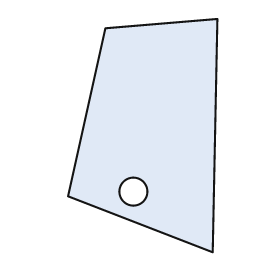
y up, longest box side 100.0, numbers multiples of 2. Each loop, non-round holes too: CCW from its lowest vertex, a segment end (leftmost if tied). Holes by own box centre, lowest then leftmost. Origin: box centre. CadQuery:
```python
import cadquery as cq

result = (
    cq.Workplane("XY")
    .moveTo(30.0, -50.0)
    .lineTo(32.0, 50.0)
    .lineTo(-16.0, 46.0)
    .lineTo(-32.0, -26.0)
    .close()
    .moveTo(-4.0, -24.0)
    .circle(6.0)
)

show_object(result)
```